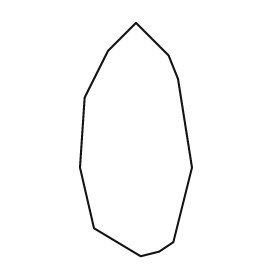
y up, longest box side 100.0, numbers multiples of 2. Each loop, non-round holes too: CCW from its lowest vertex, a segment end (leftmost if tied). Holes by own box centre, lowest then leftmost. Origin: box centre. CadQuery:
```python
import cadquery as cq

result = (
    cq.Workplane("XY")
    .moveTo(2.0, -50.0)
    .lineTo(10.0, -48.0)
    .lineTo(16.0, -44.0)
    .lineTo(24.0, -12.0)
    .lineTo(18.0, 26.0)
    .lineTo(14.0, 36.0)
    .lineTo(0.0, 50.0)
    .lineTo(-12.0, 38.0)
    .lineTo(-22.0, 18.0)
    .lineTo(-24.0, -12.0)
    .lineTo(-18.0, -38.0)
    .close()
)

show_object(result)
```